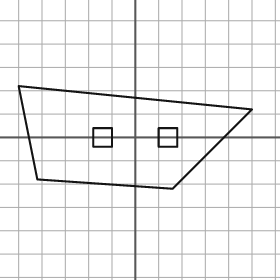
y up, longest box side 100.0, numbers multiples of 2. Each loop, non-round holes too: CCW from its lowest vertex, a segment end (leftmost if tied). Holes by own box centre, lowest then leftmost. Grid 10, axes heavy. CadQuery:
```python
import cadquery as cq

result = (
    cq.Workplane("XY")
    .moveTo(16.0, -22.0)
    .lineTo(50.0, 12.0)
    .lineTo(-50.0, 22.0)
    .lineTo(-42.0, -18.0)
    .close()
    .moveTo(-18.0, -4.0)
    .lineTo(-10.0, -4.0)
    .lineTo(-10.0, 4.0)
    .lineTo(-18.0, 4.0)
    .close()
    .moveTo(10.0, -4.0)
    .lineTo(18.0, -4.0)
    .lineTo(18.0, 4.0)
    .lineTo(10.0, 4.0)
    .close()
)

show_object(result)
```